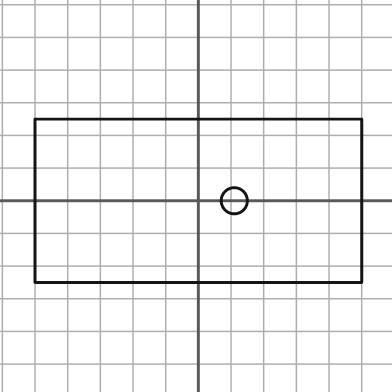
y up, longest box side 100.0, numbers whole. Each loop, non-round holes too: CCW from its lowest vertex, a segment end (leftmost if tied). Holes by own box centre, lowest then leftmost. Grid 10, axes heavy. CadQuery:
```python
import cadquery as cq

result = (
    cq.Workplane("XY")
    .moveTo(-50.0, -25.0)
    .lineTo(50.0, -25.0)
    .lineTo(50.0, 25.0)
    .lineTo(-50.0, 25.0)
    .close()
    .moveTo(11.0, 0.0)
    .circle(4.0)
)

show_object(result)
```